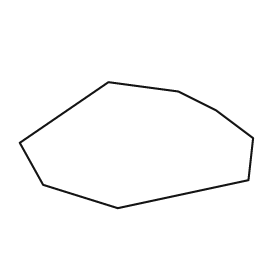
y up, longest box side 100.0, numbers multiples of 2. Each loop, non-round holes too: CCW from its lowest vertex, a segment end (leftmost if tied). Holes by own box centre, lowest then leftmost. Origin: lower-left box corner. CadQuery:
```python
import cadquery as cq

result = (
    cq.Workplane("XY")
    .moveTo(42.0, 0.0)
    .lineTo(98.0, 12.0)
    .lineTo(100.0, 30.0)
    .lineTo(84.0, 42.0)
    .lineTo(68.0, 50.0)
    .lineTo(38.0, 54.0)
    .lineTo(0.0, 28.0)
    .lineTo(10.0, 10.0)
    .close()
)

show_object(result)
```